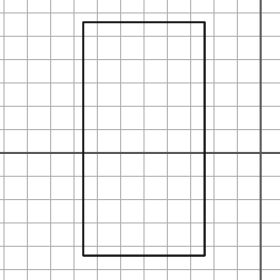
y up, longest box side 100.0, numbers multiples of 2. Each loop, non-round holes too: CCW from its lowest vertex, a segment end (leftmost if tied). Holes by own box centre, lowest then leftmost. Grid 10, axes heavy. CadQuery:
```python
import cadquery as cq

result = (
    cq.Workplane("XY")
    .moveTo(-76.0, -44.0)
    .lineTo(-24.0, -44.0)
    .lineTo(-24.0, 56.0)
    .lineTo(-76.0, 56.0)
    .close()
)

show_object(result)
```